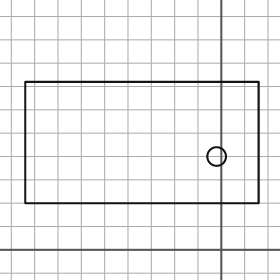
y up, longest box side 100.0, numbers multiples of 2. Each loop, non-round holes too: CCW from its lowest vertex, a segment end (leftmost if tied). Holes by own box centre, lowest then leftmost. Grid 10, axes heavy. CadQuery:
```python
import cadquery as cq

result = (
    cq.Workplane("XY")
    .moveTo(-84.0, 20.0)
    .lineTo(16.0, 20.0)
    .lineTo(16.0, 72.0)
    .lineTo(-84.0, 72.0)
    .close()
    .moveTo(-2.0, 40.0)
    .circle(4.0)
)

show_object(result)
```